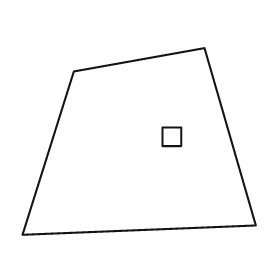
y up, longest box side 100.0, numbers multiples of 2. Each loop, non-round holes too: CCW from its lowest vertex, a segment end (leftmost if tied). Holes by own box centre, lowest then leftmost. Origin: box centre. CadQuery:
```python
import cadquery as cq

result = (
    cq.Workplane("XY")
    .moveTo(-50.0, -40.0)
    .lineTo(50.0, -36.0)
    .lineTo(28.0, 40.0)
    .lineTo(-28.0, 30.0)
    .close()
    .moveTo(10.0, -2.0)
    .lineTo(18.0, -2.0)
    .lineTo(18.0, 6.0)
    .lineTo(10.0, 6.0)
    .close()
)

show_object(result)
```